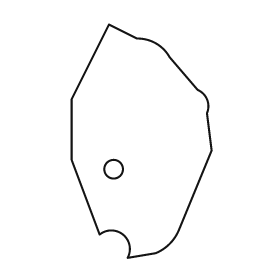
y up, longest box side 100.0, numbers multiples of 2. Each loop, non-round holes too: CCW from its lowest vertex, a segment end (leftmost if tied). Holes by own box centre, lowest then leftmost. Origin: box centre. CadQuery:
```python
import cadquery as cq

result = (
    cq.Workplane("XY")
    .moveTo(-6.0, -50.0)
    .lineTo(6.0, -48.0)
    .threePointArc((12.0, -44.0), (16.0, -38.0))
    .lineTo(30.0, -4.0)
    .lineTo(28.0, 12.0)
    .threePointArc((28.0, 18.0), (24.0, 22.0))
    .lineTo(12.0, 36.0)
    .threePointArc((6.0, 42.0), (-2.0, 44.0))
    .lineTo(-14.0, 50.0)
    .lineTo(-30.0, 18.0)
    .lineTo(-30.0, -8.0)
    .lineTo(-18.0, -40.0)
    .threePointArc((-8.0, -40.0), (-6.0, -50.0))
    .close()
    .moveTo(-12.0, -12.0)
    .circle(4.0)
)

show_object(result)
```